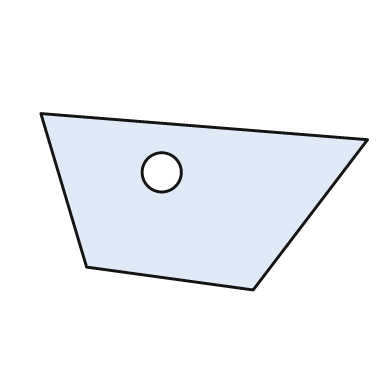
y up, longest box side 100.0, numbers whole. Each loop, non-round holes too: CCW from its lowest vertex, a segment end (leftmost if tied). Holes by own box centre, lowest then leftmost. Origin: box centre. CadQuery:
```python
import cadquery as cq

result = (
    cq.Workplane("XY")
    .moveTo(15.0, -27.0)
    .lineTo(50.0, 19.0)
    .lineTo(-50.0, 27.0)
    .lineTo(-36.0, -20.0)
    .close()
    .moveTo(-13.0, 9.0)
    .circle(6.0)
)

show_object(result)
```